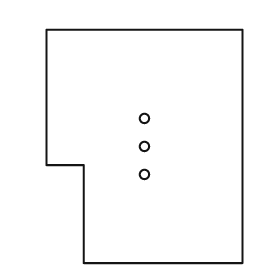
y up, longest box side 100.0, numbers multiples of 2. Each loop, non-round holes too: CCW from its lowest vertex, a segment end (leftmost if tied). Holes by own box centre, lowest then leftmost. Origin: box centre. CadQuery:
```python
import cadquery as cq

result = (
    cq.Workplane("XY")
    .moveTo(-26.0, -50.0)
    .lineTo(42.0, -50.0)
    .lineTo(42.0, 50.0)
    .lineTo(-42.0, 50.0)
    .lineTo(-42.0, -8.0)
    .lineTo(-26.0, -8.0)
    .close()
    .moveTo(0.0, -12.0)
    .circle(2.0)
    .moveTo(0.0, 0.0)
    .circle(2.0)
    .moveTo(0.0, 12.0)
    .circle(2.0)
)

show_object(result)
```